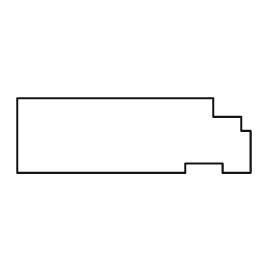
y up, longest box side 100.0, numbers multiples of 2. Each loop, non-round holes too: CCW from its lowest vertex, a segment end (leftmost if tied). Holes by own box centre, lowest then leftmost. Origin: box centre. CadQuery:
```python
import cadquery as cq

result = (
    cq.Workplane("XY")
    .moveTo(-50.0, -16.0)
    .lineTo(22.0, -16.0)
    .lineTo(22.0, -12.0)
    .lineTo(38.0, -12.0)
    .lineTo(38.0, -16.0)
    .lineTo(50.0, -16.0)
    .lineTo(50.0, 2.0)
    .lineTo(46.0, 2.0)
    .lineTo(46.0, 8.0)
    .lineTo(34.0, 8.0)
    .lineTo(34.0, 16.0)
    .lineTo(-50.0, 16.0)
    .close()
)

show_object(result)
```